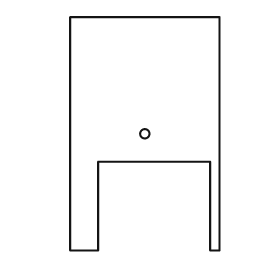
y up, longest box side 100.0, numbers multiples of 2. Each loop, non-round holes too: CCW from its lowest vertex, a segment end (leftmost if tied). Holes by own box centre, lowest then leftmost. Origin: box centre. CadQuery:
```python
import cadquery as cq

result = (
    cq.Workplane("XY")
    .moveTo(-32.0, -50.0)
    .lineTo(-20.0, -50.0)
    .lineTo(-20.0, -12.0)
    .lineTo(28.0, -12.0)
    .lineTo(28.0, -50.0)
    .lineTo(32.0, -50.0)
    .lineTo(32.0, 50.0)
    .lineTo(-32.0, 50.0)
    .close()
    .moveTo(0.0, 0.0)
    .circle(2.0)
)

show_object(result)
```